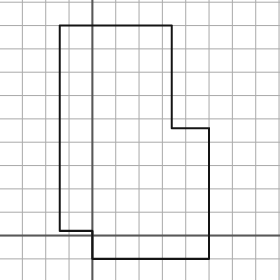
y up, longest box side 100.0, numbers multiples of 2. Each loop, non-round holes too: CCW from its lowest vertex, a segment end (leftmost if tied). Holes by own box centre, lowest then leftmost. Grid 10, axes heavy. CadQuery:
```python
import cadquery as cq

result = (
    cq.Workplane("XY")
    .moveTo(0.0, -10.0)
    .lineTo(50.0, -10.0)
    .lineTo(50.0, 46.0)
    .lineTo(34.0, 46.0)
    .lineTo(34.0, 90.0)
    .lineTo(-14.0, 90.0)
    .lineTo(-14.0, 2.0)
    .lineTo(0.0, 2.0)
    .close()
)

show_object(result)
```